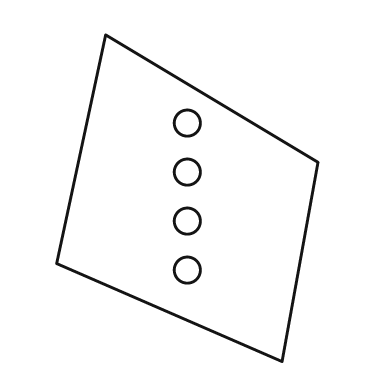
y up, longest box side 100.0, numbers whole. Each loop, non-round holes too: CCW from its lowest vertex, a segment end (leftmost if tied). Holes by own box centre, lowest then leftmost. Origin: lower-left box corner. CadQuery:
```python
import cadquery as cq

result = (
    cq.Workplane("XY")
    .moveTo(69.0, 0.0)
    .lineTo(80.0, 61.0)
    .lineTo(15.0, 100.0)
    .lineTo(0.0, 30.0)
    .close()
    .moveTo(40.0, 28.0)
    .circle(4.0)
    .moveTo(40.0, 43.0)
    .circle(4.0)
    .moveTo(40.0, 58.0)
    .circle(4.0)
    .moveTo(40.0, 73.0)
    .circle(4.0)
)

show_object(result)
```